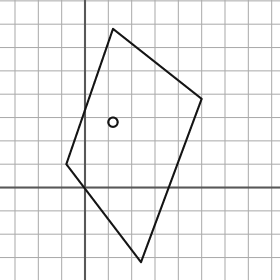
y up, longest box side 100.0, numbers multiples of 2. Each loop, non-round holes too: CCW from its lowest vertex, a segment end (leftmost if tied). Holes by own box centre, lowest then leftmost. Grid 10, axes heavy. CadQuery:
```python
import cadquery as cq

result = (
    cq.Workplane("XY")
    .moveTo(24.0, -32.0)
    .lineTo(50.0, 38.0)
    .lineTo(12.0, 68.0)
    .lineTo(-8.0, 10.0)
    .close()
    .moveTo(12.0, 28.0)
    .circle(2.0)
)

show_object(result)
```